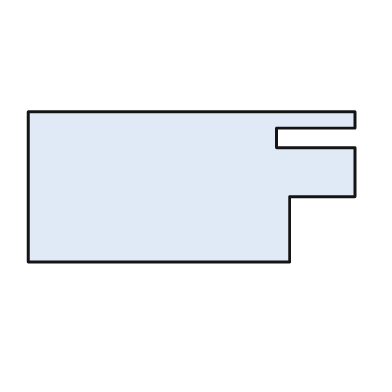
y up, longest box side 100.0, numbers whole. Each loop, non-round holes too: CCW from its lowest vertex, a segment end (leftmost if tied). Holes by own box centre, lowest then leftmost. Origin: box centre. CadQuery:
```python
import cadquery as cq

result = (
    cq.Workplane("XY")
    .moveTo(-50.0, -23.0)
    .lineTo(30.0, -23.0)
    .lineTo(30.0, -3.0)
    .lineTo(50.0, -3.0)
    .lineTo(50.0, 12.0)
    .lineTo(26.0, 12.0)
    .lineTo(26.0, 18.0)
    .lineTo(50.0, 18.0)
    .lineTo(50.0, 23.0)
    .lineTo(-50.0, 23.0)
    .close()
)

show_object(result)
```